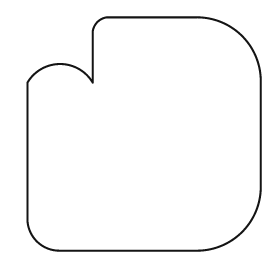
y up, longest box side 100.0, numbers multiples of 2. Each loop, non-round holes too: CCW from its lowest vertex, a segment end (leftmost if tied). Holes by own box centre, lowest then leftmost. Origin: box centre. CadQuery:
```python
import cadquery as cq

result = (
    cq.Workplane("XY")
    .moveTo(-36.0, -50.0)
    .lineTo(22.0, -50.0)
    .threePointArc((42.0, -42.0), (50.0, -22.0))
    .lineTo(50.0, 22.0)
    .threePointArc((42.0, 42.0), (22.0, 50.0))
    .lineTo(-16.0, 50.0)
    .threePointArc((-20.0, 48.0), (-22.0, 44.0))
    .lineTo(-22.0, 22.0)
    .threePointArc((-36.0, 30.0), (-50.0, 22.0))
    .lineTo(-50.0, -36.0)
    .threePointArc((-46.0, -46.0), (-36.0, -50.0))
    .close()
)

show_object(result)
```